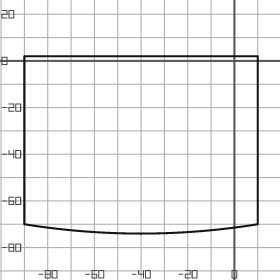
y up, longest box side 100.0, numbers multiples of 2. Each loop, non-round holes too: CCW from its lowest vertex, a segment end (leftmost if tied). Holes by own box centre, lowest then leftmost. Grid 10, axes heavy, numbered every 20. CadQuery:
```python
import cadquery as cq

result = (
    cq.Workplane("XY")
    .moveTo(-90.0, -70.0)
    .threePointArc((-40.0, -74.0), (10.0, -70.0))
    .lineTo(10.0, 2.0)
    .lineTo(-90.0, 2.0)
    .close()
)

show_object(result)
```